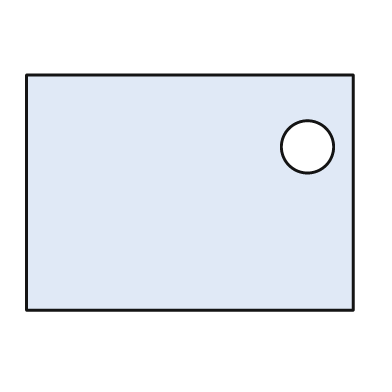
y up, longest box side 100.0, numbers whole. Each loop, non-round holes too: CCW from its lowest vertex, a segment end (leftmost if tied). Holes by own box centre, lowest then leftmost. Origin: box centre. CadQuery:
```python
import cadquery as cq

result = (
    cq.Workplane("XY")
    .moveTo(-50.0, -36.0)
    .lineTo(50.0, -36.0)
    .lineTo(50.0, 36.0)
    .lineTo(-50.0, 36.0)
    .close()
    .moveTo(36.0, 14.0)
    .circle(8.0)
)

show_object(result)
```